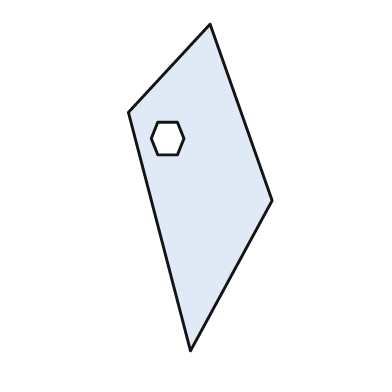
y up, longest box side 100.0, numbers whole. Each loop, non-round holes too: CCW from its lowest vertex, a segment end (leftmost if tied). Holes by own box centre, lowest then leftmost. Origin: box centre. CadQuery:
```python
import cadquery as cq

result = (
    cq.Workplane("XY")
    .moveTo(-3.0, -50.0)
    .lineTo(22.0, -4.0)
    .lineTo(3.0, 50.0)
    .lineTo(-22.0, 23.0)
    .close()
    .moveTo(-13.0, 10.0)
    .lineTo(-7.0, 10.0)
    .lineTo(-5.0, 15.0)
    .lineTo(-7.0, 20.0)
    .lineTo(-13.0, 20.0)
    .lineTo(-15.0, 15.0)
    .close()
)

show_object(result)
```